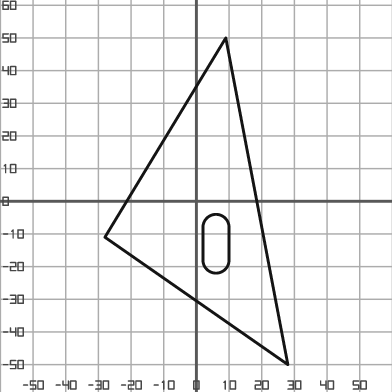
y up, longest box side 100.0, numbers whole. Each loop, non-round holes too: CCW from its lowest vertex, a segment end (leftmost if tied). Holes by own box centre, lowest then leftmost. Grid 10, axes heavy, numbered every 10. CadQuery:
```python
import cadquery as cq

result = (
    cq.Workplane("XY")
    .moveTo(28.0, -50.0)
    .lineTo(9.0, 50.0)
    .lineTo(-28.0, -11.0)
    .close()
    .moveTo(2.0, -18.0)
    .threePointArc((6.0, -22.0), (10.0, -18.0))
    .lineTo(10.0, -8.0)
    .threePointArc((6.0, -4.0), (2.0, -8.0))
    .close()
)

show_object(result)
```